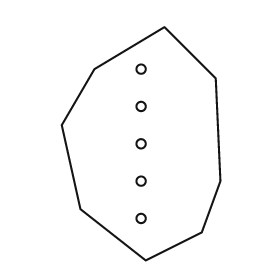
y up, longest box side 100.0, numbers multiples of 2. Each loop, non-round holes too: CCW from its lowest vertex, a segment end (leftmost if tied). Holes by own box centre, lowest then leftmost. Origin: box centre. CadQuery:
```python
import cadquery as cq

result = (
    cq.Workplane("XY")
    .moveTo(2.0, -50.0)
    .lineTo(26.0, -38.0)
    .lineTo(34.0, -16.0)
    .lineTo(32.0, 28.0)
    .lineTo(10.0, 50.0)
    .lineTo(-20.0, 32.0)
    .lineTo(-34.0, 8.0)
    .lineTo(-26.0, -28.0)
    .close()
    .moveTo(0.0, -32.0)
    .circle(2.0)
    .moveTo(0.0, -16.0)
    .circle(2.0)
    .moveTo(0.0, 0.0)
    .circle(2.0)
    .moveTo(0.0, 16.0)
    .circle(2.0)
    .moveTo(0.0, 32.0)
    .circle(2.0)
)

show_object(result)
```